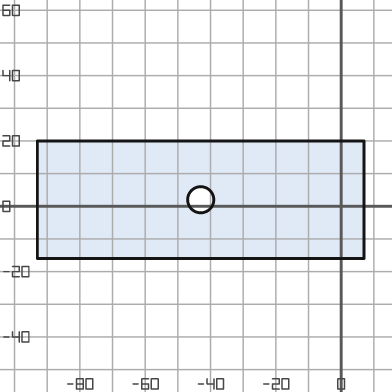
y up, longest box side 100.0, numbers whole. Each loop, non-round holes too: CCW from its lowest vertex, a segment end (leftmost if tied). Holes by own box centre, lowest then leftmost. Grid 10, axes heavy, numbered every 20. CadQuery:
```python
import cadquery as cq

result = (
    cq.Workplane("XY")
    .moveTo(-93.0, -16.0)
    .lineTo(7.0, -16.0)
    .lineTo(7.0, 20.0)
    .lineTo(-93.0, 20.0)
    .close()
    .moveTo(-43.0, 2.0)
    .circle(4.0)
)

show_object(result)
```